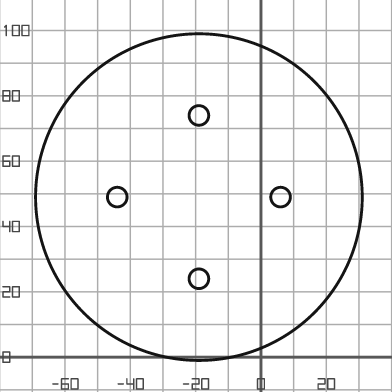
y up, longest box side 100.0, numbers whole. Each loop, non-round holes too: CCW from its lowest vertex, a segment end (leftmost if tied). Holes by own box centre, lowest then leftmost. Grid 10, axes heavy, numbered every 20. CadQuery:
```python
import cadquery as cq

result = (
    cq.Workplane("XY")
    .moveTo(-19.0, 49.0)
    .circle(50.0)
    .moveTo(-19.0, 24.0)
    .circle(3.0)
    .moveTo(-44.0, 49.0)
    .circle(3.0)
    .moveTo(6.0, 49.0)
    .circle(3.0)
    .moveTo(-19.0, 74.0)
    .circle(3.0)
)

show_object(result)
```